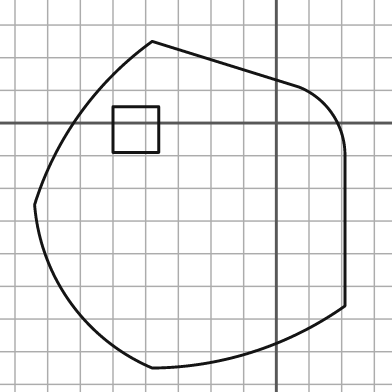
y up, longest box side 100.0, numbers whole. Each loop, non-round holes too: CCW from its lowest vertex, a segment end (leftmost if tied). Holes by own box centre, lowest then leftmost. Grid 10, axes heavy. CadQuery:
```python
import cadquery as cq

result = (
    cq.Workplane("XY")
    .moveTo(-38.0, -75.0)
    .threePointArc((-7.0, -70.0), (21.0, -56.0))
    .lineTo(21.0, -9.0)
    .threePointArc((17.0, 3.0), (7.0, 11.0))
    .lineTo(-38.0, 25.0)
    .threePointArc((-60.0, 3.0), (-74.0, -25.0))
    .threePointArc((-63.0, -55.0), (-38.0, -75.0))
    .close()
    .moveTo(-50.0, -9.0)
    .lineTo(-36.0, -9.0)
    .lineTo(-36.0, 5.0)
    .lineTo(-50.0, 5.0)
    .close()
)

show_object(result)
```